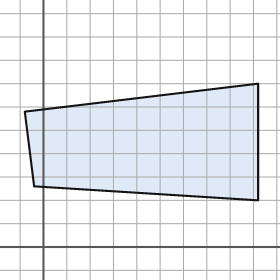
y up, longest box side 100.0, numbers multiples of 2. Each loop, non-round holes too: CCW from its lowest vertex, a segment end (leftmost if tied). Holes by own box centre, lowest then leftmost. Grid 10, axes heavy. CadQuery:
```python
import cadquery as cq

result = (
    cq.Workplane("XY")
    .moveTo(92.0, 20.0)
    .lineTo(92.0, 70.0)
    .lineTo(-8.0, 58.0)
    .lineTo(-4.0, 26.0)
    .close()
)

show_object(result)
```